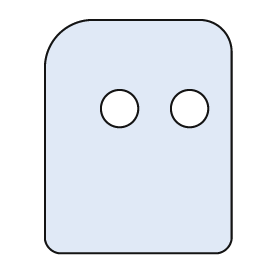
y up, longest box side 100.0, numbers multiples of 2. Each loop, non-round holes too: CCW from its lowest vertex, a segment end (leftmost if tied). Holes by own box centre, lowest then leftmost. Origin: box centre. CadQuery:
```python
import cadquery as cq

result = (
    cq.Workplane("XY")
    .moveTo(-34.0, -50.0)
    .lineTo(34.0, -50.0)
    .threePointArc((38.0, -48.0), (40.0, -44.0))
    .lineTo(40.0, 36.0)
    .threePointArc((36.0, 46.0), (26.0, 50.0))
    .lineTo(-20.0, 50.0)
    .threePointArc((-34.0, 44.0), (-40.0, 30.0))
    .lineTo(-40.0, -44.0)
    .threePointArc((-38.0, -48.0), (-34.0, -50.0))
    .close()
    .moveTo(-8.0, 12.0)
    .circle(8.0)
    .moveTo(22.0, 12.0)
    .circle(8.0)
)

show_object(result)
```